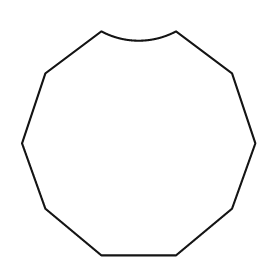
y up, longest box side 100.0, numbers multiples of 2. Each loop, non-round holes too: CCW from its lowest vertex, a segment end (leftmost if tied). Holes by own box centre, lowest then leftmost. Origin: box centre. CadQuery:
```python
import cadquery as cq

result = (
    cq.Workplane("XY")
    .moveTo(-16.0, -48.0)
    .lineTo(16.0, -48.0)
    .lineTo(40.0, -28.0)
    .lineTo(50.0, 0.0)
    .lineTo(40.0, 30.0)
    .lineTo(16.0, 48.0)
    .threePointArc((0.0, 44.0), (-16.0, 48.0))
    .lineTo(-40.0, 30.0)
    .lineTo(-50.0, 0.0)
    .lineTo(-40.0, -28.0)
    .close()
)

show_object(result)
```